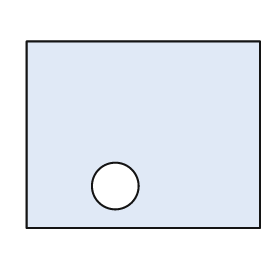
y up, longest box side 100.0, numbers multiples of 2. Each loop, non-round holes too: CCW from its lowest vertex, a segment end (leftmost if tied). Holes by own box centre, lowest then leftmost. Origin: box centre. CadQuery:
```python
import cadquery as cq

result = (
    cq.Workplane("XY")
    .moveTo(-50.0, -40.0)
    .lineTo(50.0, -40.0)
    .lineTo(50.0, 40.0)
    .lineTo(-50.0, 40.0)
    .close()
    .moveTo(-12.0, -22.0)
    .circle(10.0)
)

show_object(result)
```